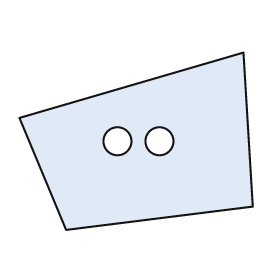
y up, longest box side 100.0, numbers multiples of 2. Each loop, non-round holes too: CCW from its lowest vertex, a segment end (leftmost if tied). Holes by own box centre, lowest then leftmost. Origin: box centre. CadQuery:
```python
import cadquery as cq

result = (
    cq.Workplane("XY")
    .moveTo(-30.0, -38.0)
    .lineTo(50.0, -28.0)
    .lineTo(46.0, 38.0)
    .lineTo(-50.0, 10.0)
    .close()
    .moveTo(-8.0, 0.0)
    .circle(6.0)
    .moveTo(10.0, 0.0)
    .circle(6.0)
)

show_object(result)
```